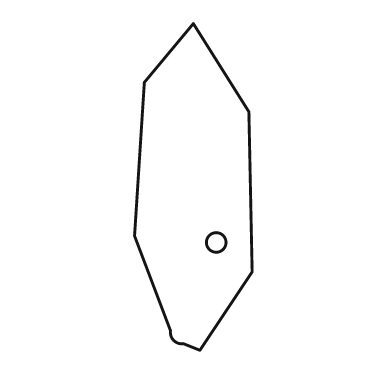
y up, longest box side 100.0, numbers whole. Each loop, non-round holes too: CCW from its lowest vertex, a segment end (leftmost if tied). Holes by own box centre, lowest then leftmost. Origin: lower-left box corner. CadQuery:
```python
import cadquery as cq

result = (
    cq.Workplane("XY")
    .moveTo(20.0, 0.0)
    .lineTo(36.0, 24.0)
    .lineTo(35.0, 73.0)
    .lineTo(18.0, 100.0)
    .lineTo(3.0, 82.0)
    .lineTo(0.0, 35.0)
    .lineTo(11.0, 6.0)
    .threePointArc((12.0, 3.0), (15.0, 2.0))
    .close()
    .moveTo(25.0, 33.0)
    .circle(3.0)
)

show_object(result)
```